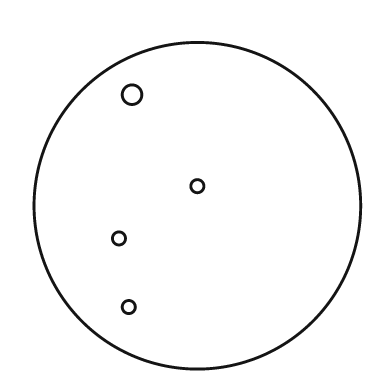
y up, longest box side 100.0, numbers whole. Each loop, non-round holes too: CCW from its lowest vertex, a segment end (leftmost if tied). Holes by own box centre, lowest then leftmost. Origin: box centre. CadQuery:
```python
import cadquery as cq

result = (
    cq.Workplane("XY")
    .moveTo(0.0, 0.0)
    .circle(50.0)
    .moveTo(-21.0, -31.0)
    .circle(2.0)
    .moveTo(-24.0, -10.0)
    .circle(2.0)
    .moveTo(0.0, 6.0)
    .circle(2.0)
    .moveTo(-20.0, 34.0)
    .circle(3.0)
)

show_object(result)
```